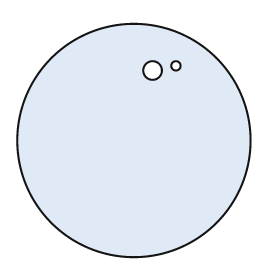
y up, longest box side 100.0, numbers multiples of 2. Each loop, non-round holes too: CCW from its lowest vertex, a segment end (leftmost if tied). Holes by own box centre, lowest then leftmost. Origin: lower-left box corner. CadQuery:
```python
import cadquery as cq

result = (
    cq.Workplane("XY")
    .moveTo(50.0, 50.0)
    .circle(50.0)
    .moveTo(58.0, 80.0)
    .circle(4.0)
    .moveTo(68.0, 82.0)
    .circle(2.0)
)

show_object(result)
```